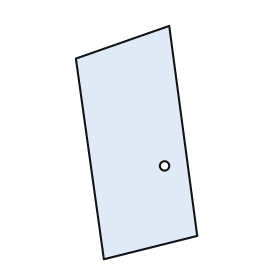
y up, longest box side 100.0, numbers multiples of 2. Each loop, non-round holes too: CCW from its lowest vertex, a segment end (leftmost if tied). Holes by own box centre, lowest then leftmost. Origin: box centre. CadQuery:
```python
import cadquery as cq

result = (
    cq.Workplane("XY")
    .moveTo(-14.0, -50.0)
    .lineTo(26.0, -40.0)
    .lineTo(14.0, 50.0)
    .lineTo(-26.0, 36.0)
    .close()
    .moveTo(12.0, -10.0)
    .circle(2.0)
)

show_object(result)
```